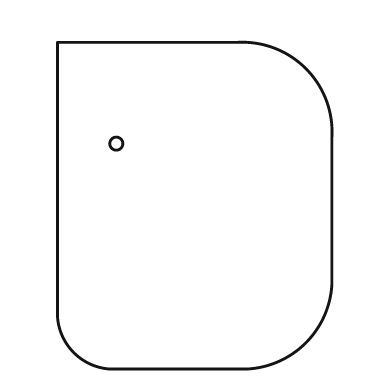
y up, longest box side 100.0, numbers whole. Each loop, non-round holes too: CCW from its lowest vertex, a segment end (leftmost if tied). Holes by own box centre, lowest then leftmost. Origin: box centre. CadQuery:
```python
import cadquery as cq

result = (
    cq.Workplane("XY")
    .moveTo(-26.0, -50.0)
    .lineTo(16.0, -50.0)
    .threePointArc((34.0, -42.0), (42.0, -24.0))
    .lineTo(42.0, 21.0)
    .threePointArc((34.0, 42.0), (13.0, 50.0))
    .lineTo(-42.0, 50.0)
    .lineTo(-42.0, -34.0)
    .threePointArc((-37.0, -45.0), (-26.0, -50.0))
    .close()
    .moveTo(-24.0, 19.0)
    .circle(2.0)
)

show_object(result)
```